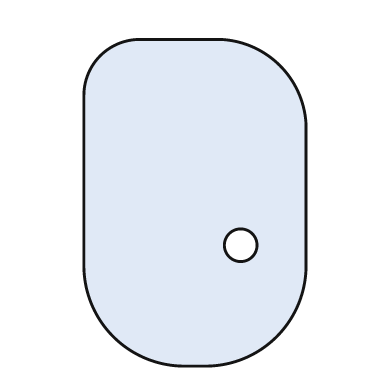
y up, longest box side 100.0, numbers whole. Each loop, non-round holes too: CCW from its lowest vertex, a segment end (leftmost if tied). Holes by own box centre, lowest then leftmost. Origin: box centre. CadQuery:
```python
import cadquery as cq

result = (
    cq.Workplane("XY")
    .moveTo(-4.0, -50.0)
    .lineTo(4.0, -50.0)
    .threePointArc((25.0, -41.0), (34.0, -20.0))
    .lineTo(34.0, 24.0)
    .threePointArc((26.0, 42.0), (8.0, 50.0))
    .lineTo(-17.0, 50.0)
    .threePointArc((-29.0, 45.0), (-34.0, 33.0))
    .lineTo(-34.0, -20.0)
    .threePointArc((-25.0, -41.0), (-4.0, -50.0))
    .close()
    .moveTo(14.0, -13.0)
    .circle(5.0)
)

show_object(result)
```